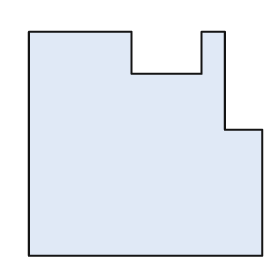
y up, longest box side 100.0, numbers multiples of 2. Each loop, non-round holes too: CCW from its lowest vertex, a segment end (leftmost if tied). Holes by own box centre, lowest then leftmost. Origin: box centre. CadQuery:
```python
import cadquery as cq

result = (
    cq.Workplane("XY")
    .moveTo(-50.0, -48.0)
    .lineTo(50.0, -48.0)
    .lineTo(50.0, 6.0)
    .lineTo(34.0, 6.0)
    .lineTo(34.0, 48.0)
    .lineTo(24.0, 48.0)
    .lineTo(24.0, 30.0)
    .lineTo(-6.0, 30.0)
    .lineTo(-6.0, 48.0)
    .lineTo(-50.0, 48.0)
    .close()
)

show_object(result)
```